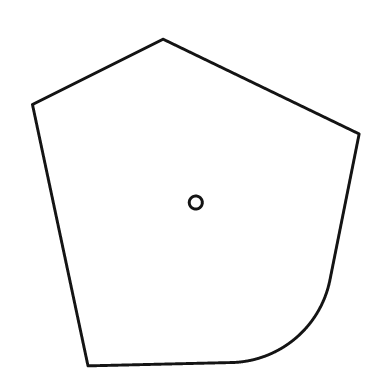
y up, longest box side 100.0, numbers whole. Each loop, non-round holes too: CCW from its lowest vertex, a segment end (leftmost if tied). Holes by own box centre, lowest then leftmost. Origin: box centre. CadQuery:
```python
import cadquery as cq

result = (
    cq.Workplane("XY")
    .moveTo(-33.0, -50.0)
    .lineTo(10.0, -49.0)
    .threePointArc((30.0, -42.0), (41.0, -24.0))
    .lineTo(50.0, 21.0)
    .lineTo(-10.0, 50.0)
    .lineTo(-50.0, 30.0)
    .close()
    .moveTo(0.0, 0.0)
    .circle(2.0)
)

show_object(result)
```